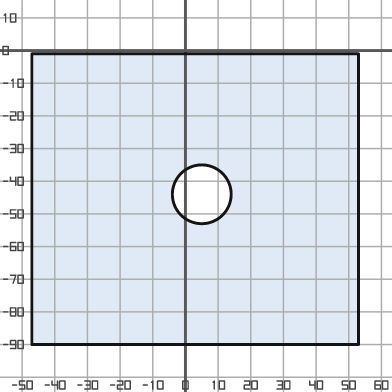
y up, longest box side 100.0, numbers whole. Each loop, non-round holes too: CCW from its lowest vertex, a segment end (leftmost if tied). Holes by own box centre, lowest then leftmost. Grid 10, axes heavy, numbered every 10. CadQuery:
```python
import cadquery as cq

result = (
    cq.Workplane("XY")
    .moveTo(-47.0, -90.0)
    .lineTo(53.0, -90.0)
    .lineTo(53.0, -1.0)
    .lineTo(-47.0, -1.0)
    .close()
    .moveTo(5.0, -44.0)
    .circle(9.0)
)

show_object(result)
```